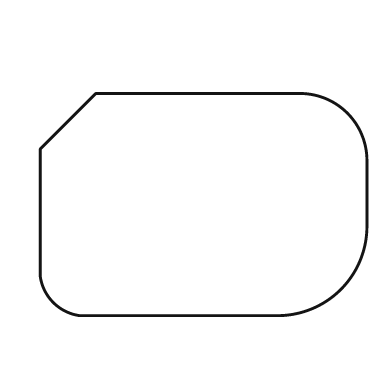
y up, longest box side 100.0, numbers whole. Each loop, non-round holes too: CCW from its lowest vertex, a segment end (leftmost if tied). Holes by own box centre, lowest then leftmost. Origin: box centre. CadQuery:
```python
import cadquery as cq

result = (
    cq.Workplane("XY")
    .moveTo(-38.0, -34.0)
    .lineTo(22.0, -34.0)
    .threePointArc((42.0, -26.0), (50.0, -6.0))
    .lineTo(50.0, 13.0)
    .threePointArc((44.0, 28.0), (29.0, 34.0))
    .lineTo(-33.0, 34.0)
    .lineTo(-50.0, 17.0)
    .lineTo(-50.0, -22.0)
    .threePointArc((-46.0, -30.0), (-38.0, -34.0))
    .close()
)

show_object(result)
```